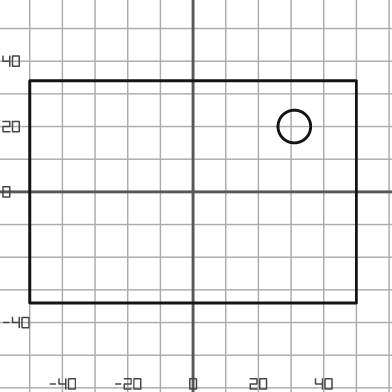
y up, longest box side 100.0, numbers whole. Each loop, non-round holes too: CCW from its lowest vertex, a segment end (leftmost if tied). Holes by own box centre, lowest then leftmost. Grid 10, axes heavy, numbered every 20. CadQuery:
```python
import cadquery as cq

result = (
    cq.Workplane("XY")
    .moveTo(-50.0, -34.0)
    .lineTo(50.0, -34.0)
    .lineTo(50.0, 34.0)
    .lineTo(-50.0, 34.0)
    .close()
    .moveTo(31.0, 20.0)
    .circle(5.0)
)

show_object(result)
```